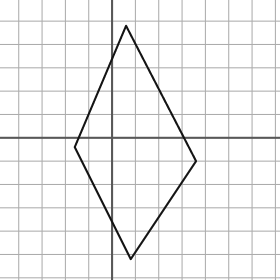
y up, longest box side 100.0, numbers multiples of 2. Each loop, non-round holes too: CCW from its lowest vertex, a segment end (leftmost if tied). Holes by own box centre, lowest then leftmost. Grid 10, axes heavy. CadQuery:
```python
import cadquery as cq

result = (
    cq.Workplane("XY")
    .moveTo(8.0, -52.0)
    .lineTo(36.0, -10.0)
    .lineTo(6.0, 48.0)
    .lineTo(-16.0, -4.0)
    .close()
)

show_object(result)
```